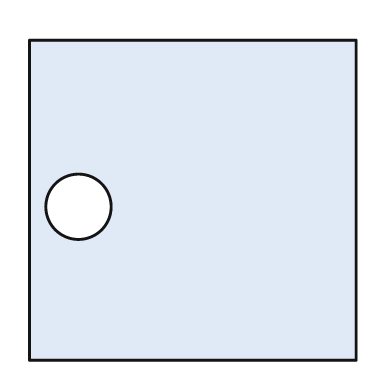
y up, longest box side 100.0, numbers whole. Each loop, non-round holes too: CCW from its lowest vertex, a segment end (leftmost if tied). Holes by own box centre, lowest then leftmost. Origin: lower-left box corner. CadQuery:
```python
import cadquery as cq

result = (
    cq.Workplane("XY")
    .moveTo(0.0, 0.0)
    .lineTo(100.0, 0.0)
    .lineTo(100.0, 98.0)
    .lineTo(0.0, 98.0)
    .close()
    .moveTo(15.0, 47.0)
    .circle(10.0)
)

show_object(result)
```